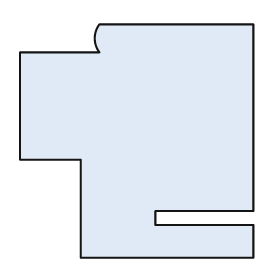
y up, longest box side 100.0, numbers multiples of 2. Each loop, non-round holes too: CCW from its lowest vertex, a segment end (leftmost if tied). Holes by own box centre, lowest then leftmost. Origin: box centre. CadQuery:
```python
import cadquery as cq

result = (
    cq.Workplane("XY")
    .moveTo(-24.0, -50.0)
    .lineTo(50.0, -50.0)
    .lineTo(50.0, -36.0)
    .lineTo(8.0, -36.0)
    .lineTo(8.0, -30.0)
    .lineTo(50.0, -30.0)
    .lineTo(50.0, 50.0)
    .lineTo(-16.0, 50.0)
    .threePointArc((-18.0, 44.0), (-16.0, 38.0))
    .lineTo(-50.0, 38.0)
    .lineTo(-50.0, -8.0)
    .lineTo(-24.0, -8.0)
    .close()
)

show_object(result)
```